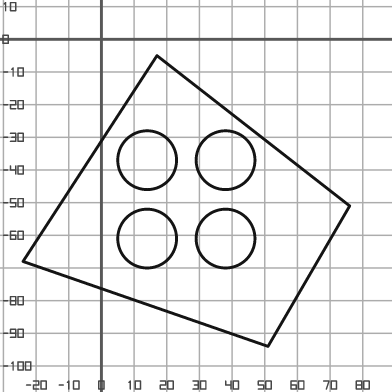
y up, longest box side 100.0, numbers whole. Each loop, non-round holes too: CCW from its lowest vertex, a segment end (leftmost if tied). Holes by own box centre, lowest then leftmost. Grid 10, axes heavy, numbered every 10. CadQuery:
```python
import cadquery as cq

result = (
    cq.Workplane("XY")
    .moveTo(51.0, -94.0)
    .lineTo(76.0, -51.0)
    .lineTo(17.0, -5.0)
    .lineTo(-24.0, -68.0)
    .close()
    .moveTo(14.0, -61.0)
    .circle(9.0)
    .moveTo(38.0, -61.0)
    .circle(9.0)
    .moveTo(14.0, -37.0)
    .circle(9.0)
    .moveTo(38.0, -37.0)
    .circle(9.0)
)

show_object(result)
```